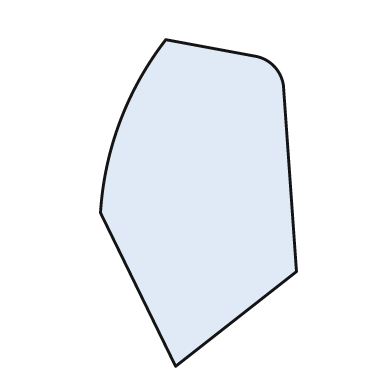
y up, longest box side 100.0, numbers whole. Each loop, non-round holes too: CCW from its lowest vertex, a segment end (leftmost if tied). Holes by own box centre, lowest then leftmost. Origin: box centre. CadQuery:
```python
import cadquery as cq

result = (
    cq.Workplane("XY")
    .moveTo(-7.0, -50.0)
    .lineTo(30.0, -21.0)
    .lineTo(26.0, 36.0)
    .threePointArc((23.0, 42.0), (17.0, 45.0))
    .lineTo(-10.0, 50.0)
    .threePointArc((-24.0, 25.0), (-30.0, -3.0))
    .close()
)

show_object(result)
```